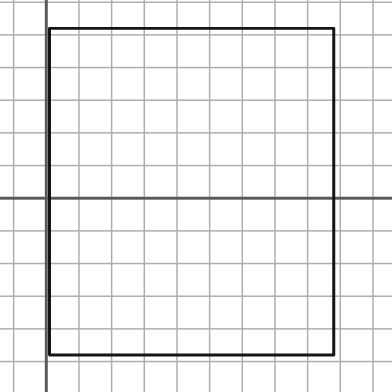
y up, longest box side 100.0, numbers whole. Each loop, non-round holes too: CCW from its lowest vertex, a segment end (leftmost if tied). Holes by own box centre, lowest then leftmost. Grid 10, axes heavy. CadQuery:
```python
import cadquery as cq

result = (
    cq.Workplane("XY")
    .moveTo(1.0, -48.0)
    .lineTo(88.0, -48.0)
    .lineTo(88.0, 52.0)
    .lineTo(1.0, 52.0)
    .close()
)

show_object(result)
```